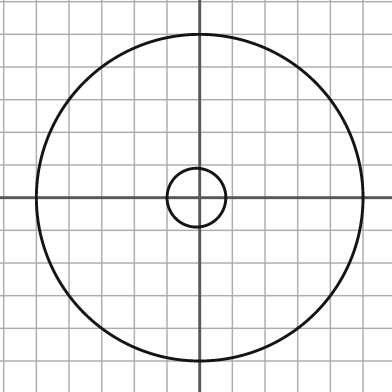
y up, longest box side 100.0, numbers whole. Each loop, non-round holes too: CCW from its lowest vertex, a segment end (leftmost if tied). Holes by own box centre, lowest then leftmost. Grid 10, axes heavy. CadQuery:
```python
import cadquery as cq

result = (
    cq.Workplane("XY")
    .moveTo(0.0, 0.0)
    .circle(50.0)
    .moveTo(-1.0, 0.0)
    .circle(9.0)
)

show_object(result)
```